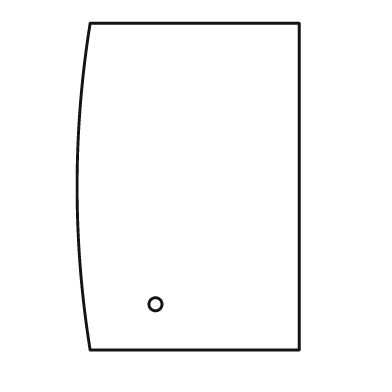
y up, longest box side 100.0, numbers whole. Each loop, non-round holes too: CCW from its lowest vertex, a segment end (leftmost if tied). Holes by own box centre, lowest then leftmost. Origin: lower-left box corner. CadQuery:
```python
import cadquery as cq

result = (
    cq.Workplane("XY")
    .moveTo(4.0, 0.0)
    .lineTo(68.0, 0.0)
    .lineTo(68.0, 100.0)
    .lineTo(4.0, 100.0)
    .threePointArc((0.0, 50.0), (4.0, 0.0))
    .close()
    .moveTo(24.0, 14.0)
    .circle(2.0)
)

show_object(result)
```